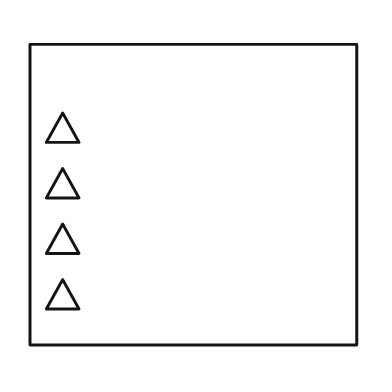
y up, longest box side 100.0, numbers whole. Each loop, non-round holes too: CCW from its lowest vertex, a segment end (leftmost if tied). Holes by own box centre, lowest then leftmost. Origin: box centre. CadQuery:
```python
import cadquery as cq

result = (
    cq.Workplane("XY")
    .moveTo(-50.0, -46.0)
    .lineTo(50.0, -46.0)
    .lineTo(50.0, 46.0)
    .lineTo(-50.0, 46.0)
    .close()
    .moveTo(-45.0, -35.0)
    .lineTo(-35.0, -35.0)
    .lineTo(-40.0, -26.0)
    .close()
    .moveTo(-45.0, -18.0)
    .lineTo(-35.0, -18.0)
    .lineTo(-40.0, -9.0)
    .close()
    .moveTo(-45.0, -1.0)
    .lineTo(-35.0, -1.0)
    .lineTo(-40.0, 8.0)
    .close()
    .moveTo(-45.0, 16.0)
    .lineTo(-35.0, 16.0)
    .lineTo(-40.0, 25.0)
    .close()
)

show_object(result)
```